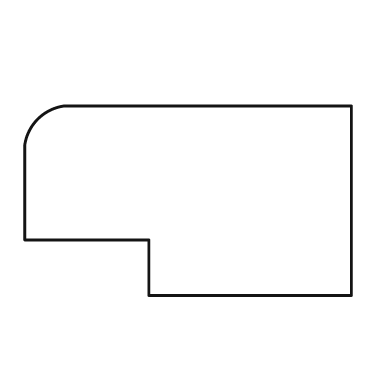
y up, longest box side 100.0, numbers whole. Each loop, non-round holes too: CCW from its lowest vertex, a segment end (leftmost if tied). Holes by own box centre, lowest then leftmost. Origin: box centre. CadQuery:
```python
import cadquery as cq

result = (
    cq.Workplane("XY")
    .moveTo(-12.0, -29.0)
    .lineTo(50.0, -29.0)
    .lineTo(50.0, 29.0)
    .lineTo(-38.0, 29.0)
    .threePointArc((-46.0, 25.0), (-50.0, 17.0))
    .lineTo(-50.0, -12.0)
    .lineTo(-12.0, -12.0)
    .close()
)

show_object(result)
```